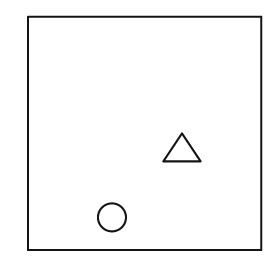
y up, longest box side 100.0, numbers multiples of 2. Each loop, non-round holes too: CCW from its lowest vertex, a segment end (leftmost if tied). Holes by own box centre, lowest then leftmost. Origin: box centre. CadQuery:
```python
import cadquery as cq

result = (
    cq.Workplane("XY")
    .moveTo(-50.0, -50.0)
    .lineTo(50.0, -50.0)
    .lineTo(50.0, 50.0)
    .lineTo(-50.0, 50.0)
    .close()
    .moveTo(-14.0, -36.0)
    .circle(6.0)
    .moveTo(8.0, -12.0)
    .lineTo(24.0, -12.0)
    .lineTo(16.0, 0.0)
    .close()
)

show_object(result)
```